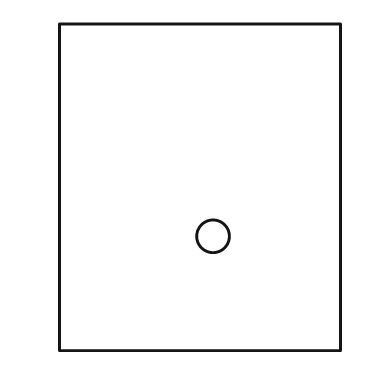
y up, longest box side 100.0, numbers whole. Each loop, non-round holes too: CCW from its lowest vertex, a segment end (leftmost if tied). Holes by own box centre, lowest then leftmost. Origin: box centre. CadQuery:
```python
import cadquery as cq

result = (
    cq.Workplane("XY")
    .moveTo(-43.0, -50.0)
    .lineTo(43.0, -50.0)
    .lineTo(43.0, 50.0)
    .lineTo(-43.0, 50.0)
    .close()
    .moveTo(4.0, -15.0)
    .circle(5.0)
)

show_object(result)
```